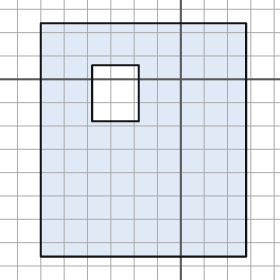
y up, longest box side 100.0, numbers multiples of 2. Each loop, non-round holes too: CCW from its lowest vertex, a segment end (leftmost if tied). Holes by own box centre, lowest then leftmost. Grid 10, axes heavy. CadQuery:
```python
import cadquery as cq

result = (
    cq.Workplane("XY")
    .moveTo(-60.0, -76.0)
    .lineTo(28.0, -76.0)
    .lineTo(28.0, 24.0)
    .lineTo(-60.0, 24.0)
    .close()
    .moveTo(-38.0, -18.0)
    .lineTo(-18.0, -18.0)
    .lineTo(-18.0, 6.0)
    .lineTo(-38.0, 6.0)
    .close()
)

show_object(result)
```